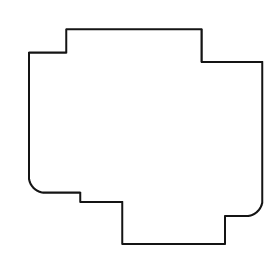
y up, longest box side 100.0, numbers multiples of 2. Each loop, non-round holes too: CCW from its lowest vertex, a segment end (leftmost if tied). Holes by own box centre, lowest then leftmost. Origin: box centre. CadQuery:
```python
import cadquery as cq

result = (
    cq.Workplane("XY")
    .moveTo(-10.0, -46.0)
    .lineTo(34.0, -46.0)
    .lineTo(34.0, -34.0)
    .lineTo(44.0, -34.0)
    .threePointArc((48.0, -32.0), (50.0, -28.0))
    .lineTo(50.0, 32.0)
    .lineTo(24.0, 32.0)
    .lineTo(24.0, 46.0)
    .lineTo(-34.0, 46.0)
    .lineTo(-34.0, 36.0)
    .lineTo(-50.0, 36.0)
    .lineTo(-50.0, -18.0)
    .threePointArc((-48.0, -22.0), (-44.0, -24.0))
    .lineTo(-28.0, -24.0)
    .lineTo(-28.0, -28.0)
    .lineTo(-10.0, -28.0)
    .close()
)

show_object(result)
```